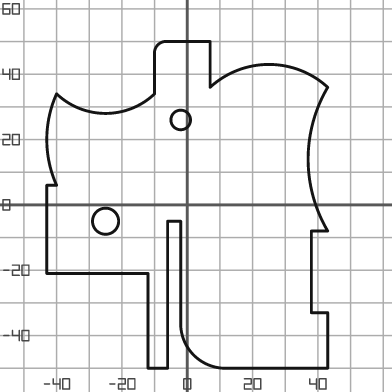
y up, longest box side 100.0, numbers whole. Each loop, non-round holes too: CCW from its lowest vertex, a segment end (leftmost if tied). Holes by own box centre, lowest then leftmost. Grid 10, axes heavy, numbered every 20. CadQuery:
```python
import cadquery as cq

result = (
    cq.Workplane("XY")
    .moveTo(-12.0, -50.0)
    .lineTo(-6.0, -50.0)
    .lineTo(-6.0, -5.0)
    .lineTo(-2.0, -5.0)
    .lineTo(-2.0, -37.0)
    .threePointArc((2.0, -46.0), (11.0, -50.0))
    .lineTo(43.0, -50.0)
    .lineTo(43.0, -33.0)
    .lineTo(38.0, -33.0)
    .lineTo(38.0, -8.0)
    .lineTo(43.0, -8.0)
    .threePointArc((37.0, 14.0), (43.0, 36.0))
    .threePointArc((25.0, 43.0), (7.0, 36.0))
    .lineTo(7.0, 50.0)
    .lineTo(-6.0, 50.0)
    .threePointArc((-9.0, 49.0), (-10.0, 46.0))
    .lineTo(-10.0, 34.0)
    .threePointArc((-25.0, 28.0), (-40.0, 34.0))
    .threePointArc((-43.0, 20.0), (-40.0, 6.0))
    .lineTo(-43.0, 6.0)
    .lineTo(-43.0, -21.0)
    .lineTo(-12.0, -21.0)
    .close()
    .moveTo(-25.0, -5.0)
    .circle(4.0)
    .moveTo(-2.0, 26.0)
    .circle(3.0)
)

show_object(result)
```